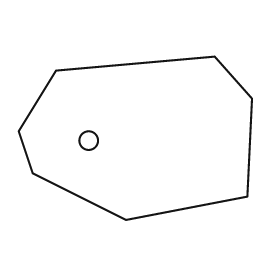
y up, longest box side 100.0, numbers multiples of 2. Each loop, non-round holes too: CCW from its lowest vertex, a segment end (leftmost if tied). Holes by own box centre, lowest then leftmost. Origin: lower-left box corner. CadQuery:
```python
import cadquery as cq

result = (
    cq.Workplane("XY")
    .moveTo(46.0, 0.0)
    .lineTo(98.0, 10.0)
    .lineTo(100.0, 52.0)
    .lineTo(84.0, 70.0)
    .lineTo(16.0, 64.0)
    .lineTo(0.0, 38.0)
    .lineTo(6.0, 20.0)
    .close()
    .moveTo(30.0, 34.0)
    .circle(4.0)
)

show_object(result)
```